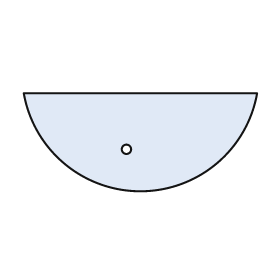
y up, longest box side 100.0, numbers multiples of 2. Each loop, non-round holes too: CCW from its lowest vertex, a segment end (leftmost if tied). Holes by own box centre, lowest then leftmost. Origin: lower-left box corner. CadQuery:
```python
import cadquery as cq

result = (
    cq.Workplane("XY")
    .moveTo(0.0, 42.0)
    .threePointArc((50.0, 0.0), (100.0, 42.0))
    .close()
    .moveTo(44.0, 18.0)
    .circle(2.0)
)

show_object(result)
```